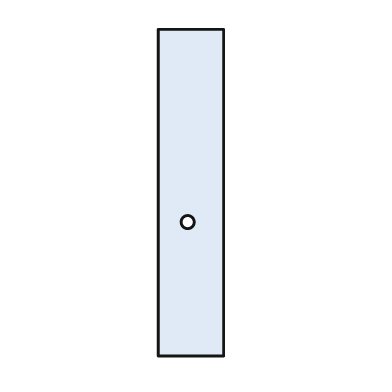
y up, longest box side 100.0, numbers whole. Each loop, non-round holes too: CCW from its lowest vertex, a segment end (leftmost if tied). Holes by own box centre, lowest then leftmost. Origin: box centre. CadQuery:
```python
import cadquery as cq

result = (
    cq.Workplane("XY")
    .moveTo(-10.0, -50.0)
    .lineTo(10.0, -50.0)
    .lineTo(10.0, 50.0)
    .lineTo(-10.0, 50.0)
    .close()
    .moveTo(-1.0, -9.0)
    .circle(2.0)
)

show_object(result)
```